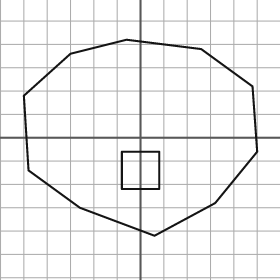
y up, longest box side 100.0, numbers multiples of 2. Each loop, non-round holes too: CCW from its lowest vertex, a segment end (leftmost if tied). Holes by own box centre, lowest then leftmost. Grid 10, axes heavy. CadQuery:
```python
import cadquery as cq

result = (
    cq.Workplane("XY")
    .moveTo(6.0, -42.0)
    .lineTo(32.0, -28.0)
    .lineTo(50.0, -6.0)
    .lineTo(48.0, 22.0)
    .lineTo(26.0, 38.0)
    .lineTo(-6.0, 42.0)
    .lineTo(-30.0, 36.0)
    .lineTo(-50.0, 18.0)
    .lineTo(-48.0, -14.0)
    .lineTo(-26.0, -30.0)
    .close()
    .moveTo(-8.0, -22.0)
    .lineTo(8.0, -22.0)
    .lineTo(8.0, -6.0)
    .lineTo(-8.0, -6.0)
    .close()
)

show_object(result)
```